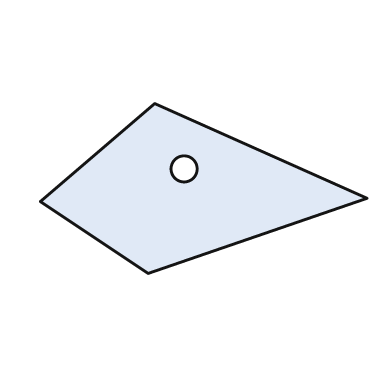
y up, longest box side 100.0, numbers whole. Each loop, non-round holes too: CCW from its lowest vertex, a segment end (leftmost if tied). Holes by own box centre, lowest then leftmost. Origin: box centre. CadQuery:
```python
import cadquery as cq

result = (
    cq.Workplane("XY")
    .moveTo(-17.0, -26.0)
    .lineTo(50.0, -3.0)
    .lineTo(-15.0, 26.0)
    .lineTo(-50.0, -4.0)
    .close()
    .moveTo(-6.0, 6.0)
    .circle(4.0)
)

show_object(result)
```